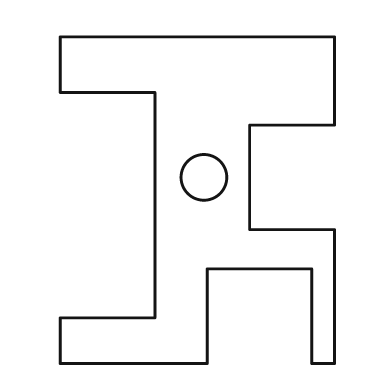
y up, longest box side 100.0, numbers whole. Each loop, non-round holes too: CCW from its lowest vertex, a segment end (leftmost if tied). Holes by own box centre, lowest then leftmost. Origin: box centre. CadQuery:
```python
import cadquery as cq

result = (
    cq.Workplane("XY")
    .moveTo(-42.0, -50.0)
    .lineTo(3.0, -50.0)
    .lineTo(3.0, -21.0)
    .lineTo(35.0, -21.0)
    .lineTo(35.0, -50.0)
    .lineTo(42.0, -50.0)
    .lineTo(42.0, -9.0)
    .lineTo(16.0, -9.0)
    .lineTo(16.0, 23.0)
    .lineTo(42.0, 23.0)
    .lineTo(42.0, 50.0)
    .lineTo(-42.0, 50.0)
    .lineTo(-42.0, 33.0)
    .lineTo(-13.0, 33.0)
    .lineTo(-13.0, -36.0)
    .lineTo(-42.0, -36.0)
    .close()
    .moveTo(2.0, 7.0)
    .circle(7.0)
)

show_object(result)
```